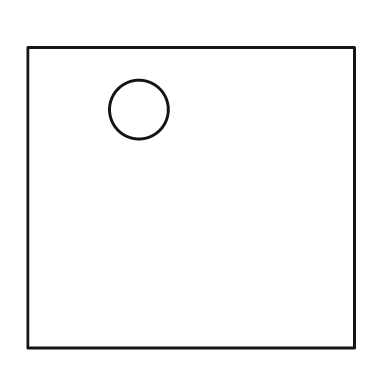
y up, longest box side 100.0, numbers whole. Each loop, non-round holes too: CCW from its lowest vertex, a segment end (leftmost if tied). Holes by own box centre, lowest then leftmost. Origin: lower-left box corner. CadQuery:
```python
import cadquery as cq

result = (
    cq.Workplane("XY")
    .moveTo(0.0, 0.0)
    .lineTo(100.0, 0.0)
    .lineTo(100.0, 92.0)
    .lineTo(0.0, 92.0)
    .close()
    .moveTo(34.0, 73.0)
    .circle(9.0)
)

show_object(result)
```